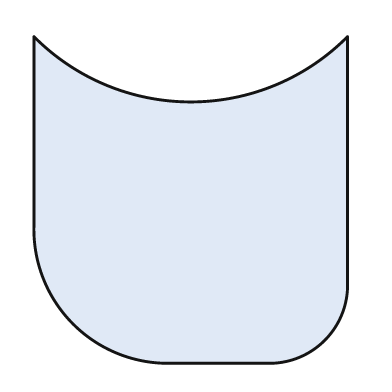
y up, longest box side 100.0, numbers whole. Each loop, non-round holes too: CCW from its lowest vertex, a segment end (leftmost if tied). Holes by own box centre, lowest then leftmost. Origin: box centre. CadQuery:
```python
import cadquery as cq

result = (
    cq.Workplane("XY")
    .moveTo(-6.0, -50.0)
    .lineTo(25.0, -50.0)
    .threePointArc((41.0, -43.0), (48.0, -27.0))
    .lineTo(48.0, 50.0)
    .threePointArc((0.0, 30.0), (-48.0, 50.0))
    .lineTo(-48.0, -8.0)
    .threePointArc((-36.0, -38.0), (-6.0, -50.0))
    .close()
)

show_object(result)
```